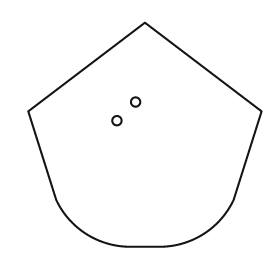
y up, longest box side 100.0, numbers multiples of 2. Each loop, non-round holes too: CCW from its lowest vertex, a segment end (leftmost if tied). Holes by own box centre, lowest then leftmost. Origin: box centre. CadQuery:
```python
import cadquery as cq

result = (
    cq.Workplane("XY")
    .moveTo(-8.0, -48.0)
    .lineTo(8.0, -48.0)
    .threePointArc((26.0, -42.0), (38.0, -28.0))
    .lineTo(50.0, 10.0)
    .lineTo(0.0, 48.0)
    .lineTo(-50.0, 10.0)
    .lineTo(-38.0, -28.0)
    .threePointArc((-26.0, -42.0), (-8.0, -48.0))
    .close()
    .moveTo(-12.0, 6.0)
    .circle(2.0)
    .moveTo(-4.0, 14.0)
    .circle(2.0)
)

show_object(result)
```